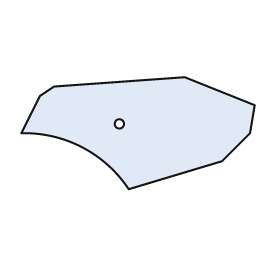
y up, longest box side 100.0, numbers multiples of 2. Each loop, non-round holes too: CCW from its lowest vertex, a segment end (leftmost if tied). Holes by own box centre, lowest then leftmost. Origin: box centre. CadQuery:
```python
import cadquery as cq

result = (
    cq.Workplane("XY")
    .moveTo(-4.0, -24.0)
    .lineTo(36.0, -12.0)
    .lineTo(48.0, 0.0)
    .lineTo(50.0, 12.0)
    .lineTo(20.0, 24.0)
    .lineTo(-36.0, 20.0)
    .lineTo(-42.0, 16.0)
    .lineTo(-50.0, 0.0)
    .threePointArc((-24.0, -6.0), (-4.0, -24.0))
    .close()
    .moveTo(-8.0, 4.0)
    .circle(2.0)
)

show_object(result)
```